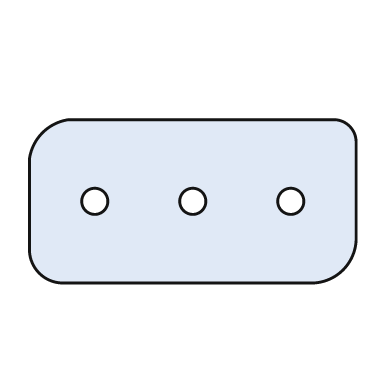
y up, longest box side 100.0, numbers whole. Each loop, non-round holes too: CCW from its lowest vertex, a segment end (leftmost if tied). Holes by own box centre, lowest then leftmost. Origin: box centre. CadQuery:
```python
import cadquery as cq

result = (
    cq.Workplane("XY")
    .moveTo(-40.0, -25.0)
    .lineTo(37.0, -25.0)
    .threePointArc((46.0, -21.0), (50.0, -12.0))
    .lineTo(50.0, 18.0)
    .threePointArc((48.0, 23.0), (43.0, 25.0))
    .lineTo(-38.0, 25.0)
    .threePointArc((-46.0, 21.0), (-50.0, 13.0))
    .lineTo(-50.0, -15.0)
    .threePointArc((-47.0, -22.0), (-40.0, -25.0))
    .close()
    .moveTo(-30.0, 0.0)
    .circle(4.0)
    .moveTo(0.0, 0.0)
    .circle(4.0)
    .moveTo(30.0, 0.0)
    .circle(4.0)
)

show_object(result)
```